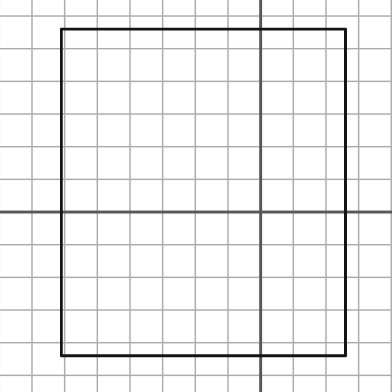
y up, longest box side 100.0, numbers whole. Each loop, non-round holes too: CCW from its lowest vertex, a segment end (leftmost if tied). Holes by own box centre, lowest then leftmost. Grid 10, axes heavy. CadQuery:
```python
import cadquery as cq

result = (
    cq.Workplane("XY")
    .moveTo(-61.0, -44.0)
    .lineTo(26.0, -44.0)
    .lineTo(26.0, 56.0)
    .lineTo(-61.0, 56.0)
    .close()
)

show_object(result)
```